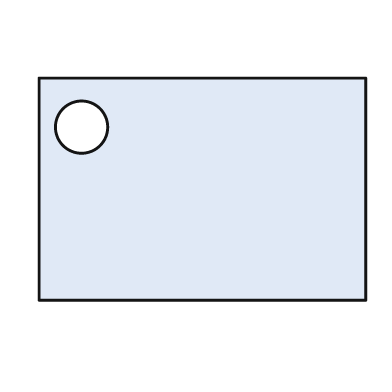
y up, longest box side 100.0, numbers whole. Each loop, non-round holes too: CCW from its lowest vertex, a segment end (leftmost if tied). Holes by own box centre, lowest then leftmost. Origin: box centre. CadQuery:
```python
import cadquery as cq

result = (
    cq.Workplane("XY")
    .moveTo(-50.0, -34.0)
    .lineTo(50.0, -34.0)
    .lineTo(50.0, 34.0)
    .lineTo(-50.0, 34.0)
    .close()
    .moveTo(-37.0, 19.0)
    .circle(8.0)
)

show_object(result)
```